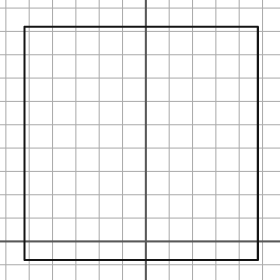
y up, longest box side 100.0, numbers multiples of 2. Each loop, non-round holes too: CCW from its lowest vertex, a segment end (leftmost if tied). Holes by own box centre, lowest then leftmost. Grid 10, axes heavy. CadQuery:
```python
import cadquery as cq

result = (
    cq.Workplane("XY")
    .moveTo(-52.0, -8.0)
    .lineTo(48.0, -8.0)
    .lineTo(48.0, 92.0)
    .lineTo(-52.0, 92.0)
    .close()
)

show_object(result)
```